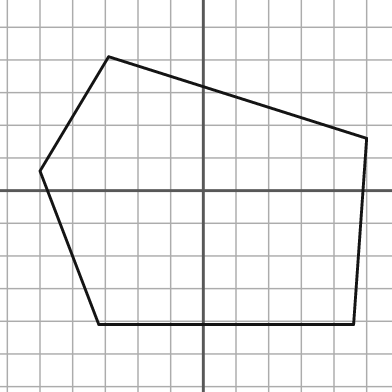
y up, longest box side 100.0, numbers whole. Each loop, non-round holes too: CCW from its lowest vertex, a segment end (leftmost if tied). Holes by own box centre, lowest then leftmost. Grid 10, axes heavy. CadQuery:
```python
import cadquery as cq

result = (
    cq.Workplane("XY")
    .moveTo(-32.0, -41.0)
    .lineTo(46.0, -41.0)
    .lineTo(50.0, 16.0)
    .lineTo(-29.0, 41.0)
    .lineTo(-50.0, 6.0)
    .close()
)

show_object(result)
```